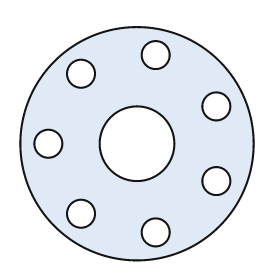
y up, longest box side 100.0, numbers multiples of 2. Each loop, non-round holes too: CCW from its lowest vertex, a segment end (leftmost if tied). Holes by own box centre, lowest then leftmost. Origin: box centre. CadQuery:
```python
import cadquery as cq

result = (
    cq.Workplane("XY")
    .moveTo(0.0, 0.0)
    .circle(50.0)
    .moveTo(8.0, -38.0)
    .circle(6.0)
    .moveTo(-24.0, -30.0)
    .circle(6.0)
    .moveTo(34.0, -16.0)
    .circle(6.0)
    .moveTo(-38.0, 0.0)
    .circle(6.0)
    .moveTo(0.0, 0.0)
    .circle(16.0)
    .moveTo(34.0, 16.0)
    .circle(6.0)
    .moveTo(-24.0, 30.0)
    .circle(6.0)
    .moveTo(8.0, 38.0)
    .circle(6.0)
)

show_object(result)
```